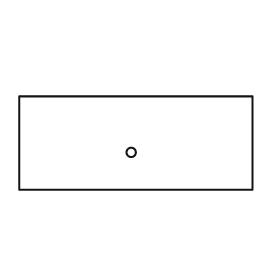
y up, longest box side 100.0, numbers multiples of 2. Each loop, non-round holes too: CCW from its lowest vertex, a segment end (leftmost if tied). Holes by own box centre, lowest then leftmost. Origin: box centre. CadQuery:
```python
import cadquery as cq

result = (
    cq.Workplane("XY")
    .moveTo(-50.0, -20.0)
    .lineTo(50.0, -20.0)
    .lineTo(50.0, 20.0)
    .lineTo(-50.0, 20.0)
    .close()
    .moveTo(-2.0, -4.0)
    .circle(2.0)
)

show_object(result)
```